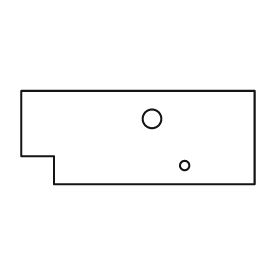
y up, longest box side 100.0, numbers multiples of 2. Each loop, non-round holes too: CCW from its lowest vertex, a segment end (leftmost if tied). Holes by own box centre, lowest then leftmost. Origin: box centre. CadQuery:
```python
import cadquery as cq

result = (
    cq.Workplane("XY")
    .moveTo(-36.0, -20.0)
    .lineTo(50.0, -20.0)
    .lineTo(50.0, 20.0)
    .lineTo(-50.0, 20.0)
    .lineTo(-50.0, -8.0)
    .lineTo(-36.0, -8.0)
    .close()
    .moveTo(20.0, -12.0)
    .circle(2.0)
    .moveTo(6.0, 8.0)
    .circle(4.0)
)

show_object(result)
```